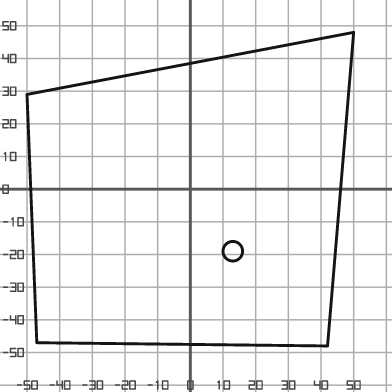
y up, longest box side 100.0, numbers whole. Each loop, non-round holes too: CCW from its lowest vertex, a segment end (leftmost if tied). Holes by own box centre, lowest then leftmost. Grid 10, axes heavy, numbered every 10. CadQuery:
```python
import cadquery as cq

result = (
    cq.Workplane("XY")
    .moveTo(42.0, -48.0)
    .lineTo(50.0, 48.0)
    .lineTo(-50.0, 29.0)
    .lineTo(-47.0, -47.0)
    .close()
    .moveTo(13.0, -19.0)
    .circle(3.0)
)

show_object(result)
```